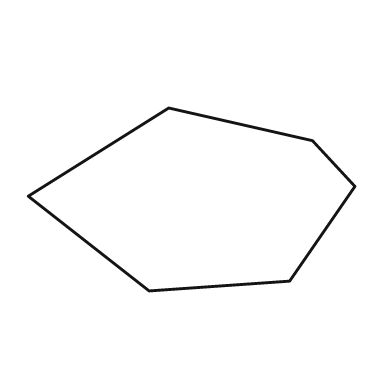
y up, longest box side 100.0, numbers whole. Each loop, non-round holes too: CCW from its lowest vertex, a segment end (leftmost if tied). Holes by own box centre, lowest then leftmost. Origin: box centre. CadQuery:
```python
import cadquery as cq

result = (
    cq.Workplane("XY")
    .moveTo(-13.0, -28.0)
    .lineTo(30.0, -25.0)
    .lineTo(50.0, 4.0)
    .lineTo(37.0, 18.0)
    .lineTo(-7.0, 28.0)
    .lineTo(-50.0, 1.0)
    .close()
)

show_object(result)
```